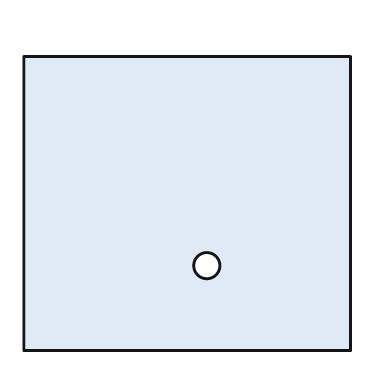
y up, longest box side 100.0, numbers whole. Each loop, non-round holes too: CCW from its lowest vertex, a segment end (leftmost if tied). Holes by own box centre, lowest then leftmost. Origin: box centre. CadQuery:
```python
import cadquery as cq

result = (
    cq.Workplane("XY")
    .moveTo(-50.0, -45.0)
    .lineTo(50.0, -45.0)
    .lineTo(50.0, 45.0)
    .lineTo(-50.0, 45.0)
    .close()
    .moveTo(6.0, -19.0)
    .circle(4.0)
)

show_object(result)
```